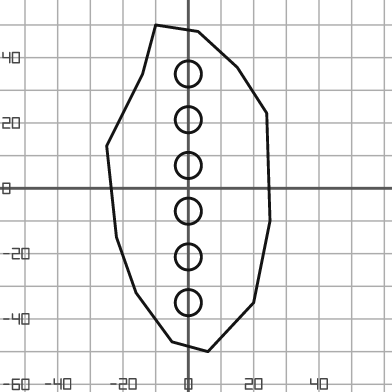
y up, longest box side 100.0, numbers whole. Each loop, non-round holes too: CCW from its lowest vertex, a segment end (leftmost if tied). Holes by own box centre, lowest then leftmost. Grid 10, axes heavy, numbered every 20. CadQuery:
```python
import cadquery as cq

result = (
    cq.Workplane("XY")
    .moveTo(6.0, -50.0)
    .lineTo(20.0, -35.0)
    .lineTo(25.0, -10.0)
    .lineTo(24.0, 23.0)
    .lineTo(15.0, 37.0)
    .lineTo(3.0, 48.0)
    .lineTo(-10.0, 50.0)
    .lineTo(-14.0, 35.0)
    .lineTo(-25.0, 13.0)
    .lineTo(-22.0, -15.0)
    .lineTo(-16.0, -32.0)
    .lineTo(-5.0, -47.0)
    .close()
    .moveTo(0.0, -35.0)
    .circle(4.0)
    .moveTo(0.0, -21.0)
    .circle(4.0)
    .moveTo(0.0, -7.0)
    .circle(4.0)
    .moveTo(0.0, 7.0)
    .circle(4.0)
    .moveTo(0.0, 21.0)
    .circle(4.0)
    .moveTo(0.0, 35.0)
    .circle(4.0)
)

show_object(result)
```